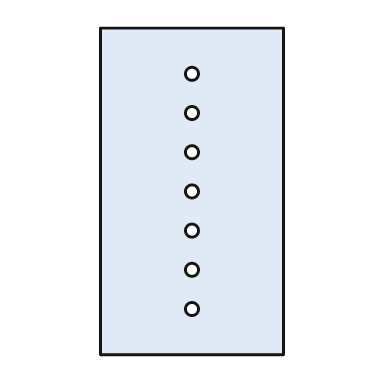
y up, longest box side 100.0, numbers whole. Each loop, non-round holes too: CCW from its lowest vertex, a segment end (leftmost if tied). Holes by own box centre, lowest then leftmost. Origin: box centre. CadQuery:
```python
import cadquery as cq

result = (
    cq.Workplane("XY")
    .moveTo(-28.0, -50.0)
    .lineTo(28.0, -50.0)
    .lineTo(28.0, 50.0)
    .lineTo(-28.0, 50.0)
    .close()
    .moveTo(0.0, -36.0)
    .circle(2.0)
    .moveTo(0.0, -24.0)
    .circle(2.0)
    .moveTo(0.0, -12.0)
    .circle(2.0)
    .moveTo(0.0, 0.0)
    .circle(2.0)
    .moveTo(0.0, 12.0)
    .circle(2.0)
    .moveTo(0.0, 24.0)
    .circle(2.0)
    .moveTo(0.0, 36.0)
    .circle(2.0)
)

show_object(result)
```